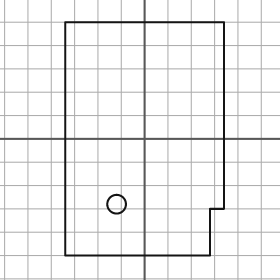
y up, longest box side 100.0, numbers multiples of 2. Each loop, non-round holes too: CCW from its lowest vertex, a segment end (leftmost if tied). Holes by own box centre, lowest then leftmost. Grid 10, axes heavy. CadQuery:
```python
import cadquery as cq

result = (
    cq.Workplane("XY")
    .moveTo(-34.0, -50.0)
    .lineTo(28.0, -50.0)
    .lineTo(28.0, -30.0)
    .lineTo(34.0, -30.0)
    .lineTo(34.0, 50.0)
    .lineTo(-34.0, 50.0)
    .close()
    .moveTo(-12.0, -28.0)
    .circle(4.0)
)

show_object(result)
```